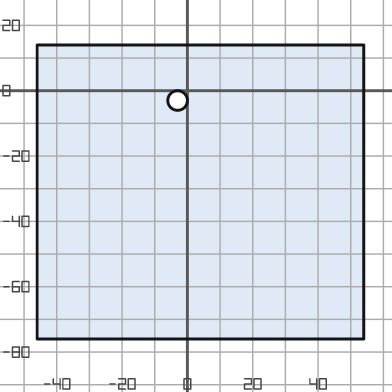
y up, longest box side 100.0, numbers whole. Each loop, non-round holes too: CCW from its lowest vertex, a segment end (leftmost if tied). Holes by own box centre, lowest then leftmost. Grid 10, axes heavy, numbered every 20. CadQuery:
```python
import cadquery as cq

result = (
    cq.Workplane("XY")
    .moveTo(-46.0, -76.0)
    .lineTo(54.0, -76.0)
    .lineTo(54.0, 14.0)
    .lineTo(-46.0, 14.0)
    .close()
    .moveTo(-3.0, -3.0)
    .circle(3.0)
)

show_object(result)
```